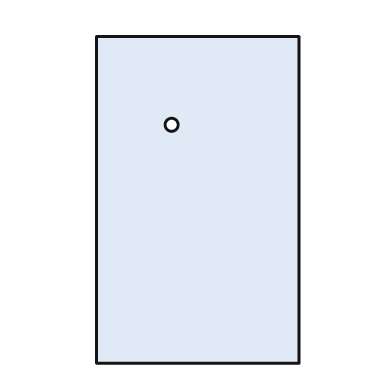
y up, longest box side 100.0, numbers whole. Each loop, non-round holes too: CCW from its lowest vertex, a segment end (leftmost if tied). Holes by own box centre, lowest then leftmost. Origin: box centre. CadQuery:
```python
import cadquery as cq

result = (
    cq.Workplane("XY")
    .moveTo(-31.0, -50.0)
    .lineTo(31.0, -50.0)
    .lineTo(31.0, 50.0)
    .lineTo(-31.0, 50.0)
    .close()
    .moveTo(-8.0, 23.0)
    .circle(2.0)
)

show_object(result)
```